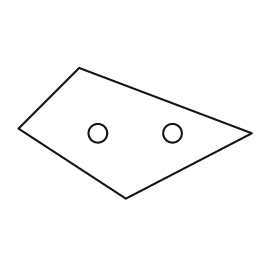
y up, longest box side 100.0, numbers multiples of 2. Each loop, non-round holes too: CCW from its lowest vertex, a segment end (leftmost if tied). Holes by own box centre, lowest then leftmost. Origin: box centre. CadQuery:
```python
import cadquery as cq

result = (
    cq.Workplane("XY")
    .moveTo(-4.0, -28.0)
    .lineTo(50.0, 0.0)
    .lineTo(-24.0, 28.0)
    .lineTo(-50.0, 2.0)
    .close()
    .moveTo(-16.0, 0.0)
    .circle(4.0)
    .moveTo(16.0, 0.0)
    .circle(4.0)
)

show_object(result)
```